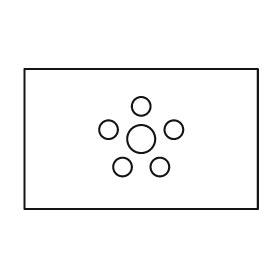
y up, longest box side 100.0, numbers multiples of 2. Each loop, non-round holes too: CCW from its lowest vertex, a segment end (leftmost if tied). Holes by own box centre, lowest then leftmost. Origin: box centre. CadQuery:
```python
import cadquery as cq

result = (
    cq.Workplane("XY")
    .moveTo(-50.0, -30.0)
    .lineTo(50.0, -30.0)
    .lineTo(50.0, 30.0)
    .lineTo(-50.0, 30.0)
    .close()
    .moveTo(-8.0, -12.0)
    .circle(4.0)
    .moveTo(8.0, -12.0)
    .circle(4.0)
    .moveTo(0.0, 0.0)
    .circle(6.0)
    .moveTo(-14.0, 4.0)
    .circle(4.0)
    .moveTo(14.0, 4.0)
    .circle(4.0)
    .moveTo(0.0, 14.0)
    .circle(4.0)
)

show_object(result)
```